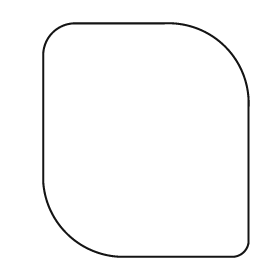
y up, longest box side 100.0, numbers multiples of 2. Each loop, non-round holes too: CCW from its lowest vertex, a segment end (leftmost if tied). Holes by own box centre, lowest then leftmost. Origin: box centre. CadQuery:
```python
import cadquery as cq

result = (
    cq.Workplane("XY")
    .moveTo(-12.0, -50.0)
    .lineTo(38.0, -50.0)
    .threePointArc((42.0, -48.0), (44.0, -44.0))
    .lineTo(44.0, 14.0)
    .threePointArc((34.0, 40.0), (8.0, 50.0))
    .lineTo(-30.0, 50.0)
    .threePointArc((-40.0, 46.0), (-44.0, 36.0))
    .lineTo(-44.0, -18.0)
    .threePointArc((-34.0, -40.0), (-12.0, -50.0))
    .close()
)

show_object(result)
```